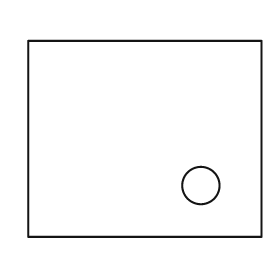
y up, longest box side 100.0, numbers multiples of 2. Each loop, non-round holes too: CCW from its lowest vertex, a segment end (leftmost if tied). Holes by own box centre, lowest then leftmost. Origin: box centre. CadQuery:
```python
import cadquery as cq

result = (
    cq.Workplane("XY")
    .moveTo(-50.0, -42.0)
    .lineTo(50.0, -42.0)
    .lineTo(50.0, 42.0)
    .lineTo(-50.0, 42.0)
    .close()
    .moveTo(24.0, -20.0)
    .circle(8.0)
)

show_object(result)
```